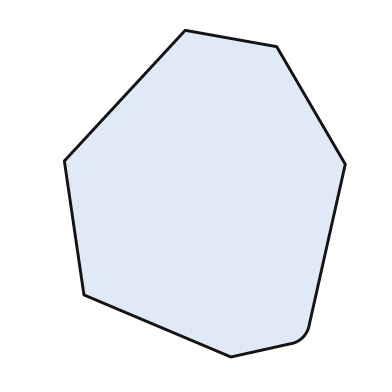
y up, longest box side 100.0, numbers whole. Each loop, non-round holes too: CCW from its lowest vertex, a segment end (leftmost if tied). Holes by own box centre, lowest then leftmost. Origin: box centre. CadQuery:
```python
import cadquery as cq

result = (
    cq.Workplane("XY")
    .moveTo(8.0, -50.0)
    .lineTo(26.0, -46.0)
    .threePointArc((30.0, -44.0), (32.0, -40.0))
    .lineTo(43.0, 9.0)
    .lineTo(22.0, 45.0)
    .lineTo(-6.0, 50.0)
    .lineTo(-43.0, 10.0)
    .lineTo(-37.0, -31.0)
    .close()
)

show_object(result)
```